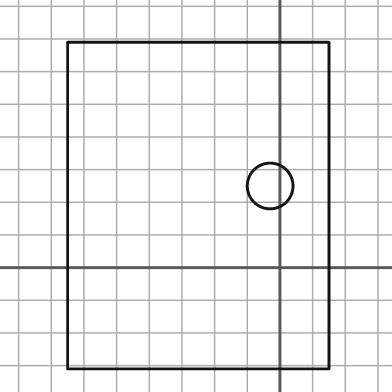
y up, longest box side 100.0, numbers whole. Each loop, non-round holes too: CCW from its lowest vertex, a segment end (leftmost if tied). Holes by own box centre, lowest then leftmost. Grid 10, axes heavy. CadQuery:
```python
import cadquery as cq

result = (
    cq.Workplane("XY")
    .moveTo(-65.0, -31.0)
    .lineTo(15.0, -31.0)
    .lineTo(15.0, 69.0)
    .lineTo(-65.0, 69.0)
    .close()
    .moveTo(-3.0, 25.0)
    .circle(7.0)
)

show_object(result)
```